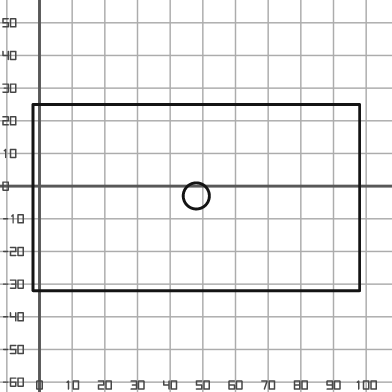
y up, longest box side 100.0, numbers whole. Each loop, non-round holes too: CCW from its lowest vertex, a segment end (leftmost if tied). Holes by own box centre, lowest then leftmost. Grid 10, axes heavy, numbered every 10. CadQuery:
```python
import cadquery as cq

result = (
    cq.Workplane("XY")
    .moveTo(-2.0, -32.0)
    .lineTo(98.0, -32.0)
    .lineTo(98.0, 25.0)
    .lineTo(-2.0, 25.0)
    .close()
    .moveTo(48.0, -3.0)
    .circle(4.0)
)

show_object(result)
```